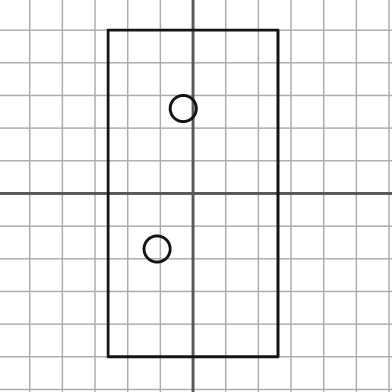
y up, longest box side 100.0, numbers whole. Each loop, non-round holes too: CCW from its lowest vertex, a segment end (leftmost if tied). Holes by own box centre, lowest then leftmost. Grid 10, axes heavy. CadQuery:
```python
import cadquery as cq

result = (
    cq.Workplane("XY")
    .moveTo(-26.0, -50.0)
    .lineTo(26.0, -50.0)
    .lineTo(26.0, 50.0)
    .lineTo(-26.0, 50.0)
    .close()
    .moveTo(-11.0, -17.0)
    .circle(4.0)
    .moveTo(-3.0, 26.0)
    .circle(4.0)
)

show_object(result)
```